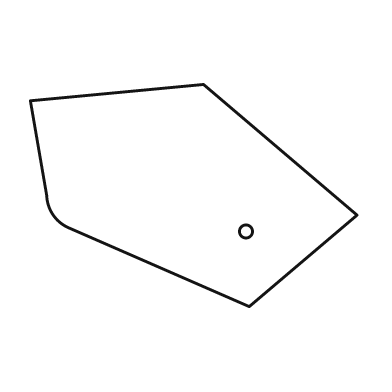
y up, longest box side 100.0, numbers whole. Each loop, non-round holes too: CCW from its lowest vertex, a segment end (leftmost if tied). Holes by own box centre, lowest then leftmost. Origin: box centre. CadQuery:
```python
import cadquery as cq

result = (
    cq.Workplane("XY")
    .moveTo(17.0, -34.0)
    .lineTo(50.0, -6.0)
    .lineTo(3.0, 34.0)
    .lineTo(-50.0, 29.0)
    .lineTo(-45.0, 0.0)
    .threePointArc((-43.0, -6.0), (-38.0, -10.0))
    .close()
    .moveTo(16.0, -11.0)
    .circle(2.0)
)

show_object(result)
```